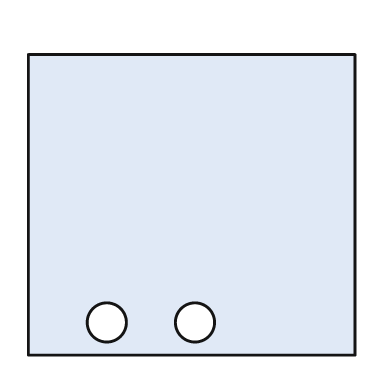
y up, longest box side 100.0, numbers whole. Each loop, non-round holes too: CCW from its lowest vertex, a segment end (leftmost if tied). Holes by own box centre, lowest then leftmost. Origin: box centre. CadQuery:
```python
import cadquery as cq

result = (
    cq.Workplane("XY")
    .moveTo(-50.0, -46.0)
    .lineTo(50.0, -46.0)
    .lineTo(50.0, 46.0)
    .lineTo(-50.0, 46.0)
    .close()
    .moveTo(-26.0, -36.0)
    .circle(6.0)
    .moveTo(1.0, -36.0)
    .circle(6.0)
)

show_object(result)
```